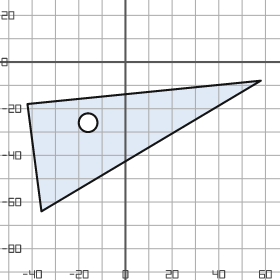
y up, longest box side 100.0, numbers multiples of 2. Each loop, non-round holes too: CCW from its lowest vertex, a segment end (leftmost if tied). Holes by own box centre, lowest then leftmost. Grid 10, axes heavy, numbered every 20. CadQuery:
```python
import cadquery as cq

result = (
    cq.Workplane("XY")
    .moveTo(-36.0, -64.0)
    .lineTo(58.0, -8.0)
    .lineTo(-42.0, -18.0)
    .close()
    .moveTo(-16.0, -26.0)
    .circle(4.0)
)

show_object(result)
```